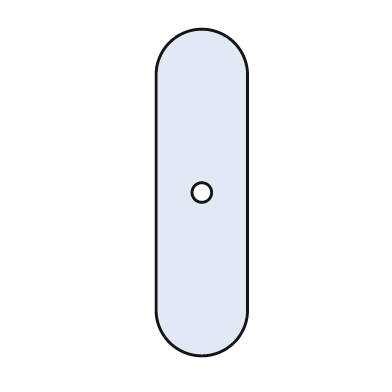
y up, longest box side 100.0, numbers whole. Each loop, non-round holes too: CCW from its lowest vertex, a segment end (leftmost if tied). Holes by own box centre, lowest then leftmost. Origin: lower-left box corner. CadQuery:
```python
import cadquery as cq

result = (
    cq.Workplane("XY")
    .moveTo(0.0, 14.0)
    .threePointArc((14.0, 0.0), (28.0, 14.0))
    .lineTo(28.0, 86.0)
    .threePointArc((14.0, 100.0), (0.0, 86.0))
    .close()
    .moveTo(14.0, 50.0)
    .circle(3.0)
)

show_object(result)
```